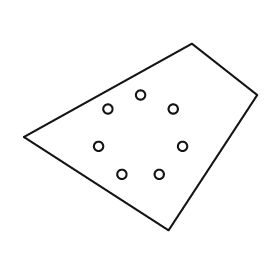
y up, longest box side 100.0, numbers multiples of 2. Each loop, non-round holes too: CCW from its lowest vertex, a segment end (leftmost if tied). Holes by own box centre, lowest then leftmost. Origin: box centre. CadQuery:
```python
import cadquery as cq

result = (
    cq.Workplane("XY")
    .moveTo(12.0, -40.0)
    .lineTo(50.0, 18.0)
    .lineTo(22.0, 40.0)
    .lineTo(-50.0, 0.0)
    .close()
    .moveTo(-8.0, -16.0)
    .circle(2.0)
    .moveTo(8.0, -16.0)
    .circle(2.0)
    .moveTo(-18.0, -4.0)
    .circle(2.0)
    .moveTo(18.0, -4.0)
    .circle(2.0)
    .moveTo(-14.0, 12.0)
    .circle(2.0)
    .moveTo(14.0, 12.0)
    .circle(2.0)
    .moveTo(0.0, 18.0)
    .circle(2.0)
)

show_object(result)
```